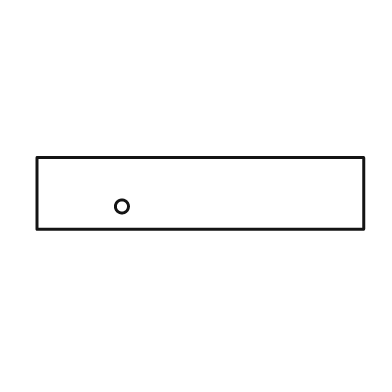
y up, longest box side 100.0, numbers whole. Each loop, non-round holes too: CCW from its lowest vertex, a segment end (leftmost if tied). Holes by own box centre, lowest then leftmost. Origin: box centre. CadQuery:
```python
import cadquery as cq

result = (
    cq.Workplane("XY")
    .moveTo(-50.0, -11.0)
    .lineTo(50.0, -11.0)
    .lineTo(50.0, 11.0)
    .lineTo(-50.0, 11.0)
    .close()
    .moveTo(-24.0, -4.0)
    .circle(2.0)
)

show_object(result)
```